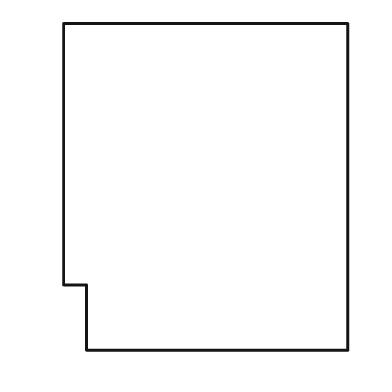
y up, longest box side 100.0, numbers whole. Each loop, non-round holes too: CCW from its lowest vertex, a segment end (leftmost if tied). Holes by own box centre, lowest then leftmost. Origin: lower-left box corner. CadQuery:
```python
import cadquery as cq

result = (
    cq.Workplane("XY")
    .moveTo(7.0, 0.0)
    .lineTo(87.0, 0.0)
    .lineTo(87.0, 100.0)
    .lineTo(0.0, 100.0)
    .lineTo(0.0, 20.0)
    .lineTo(7.0, 20.0)
    .close()
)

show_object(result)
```